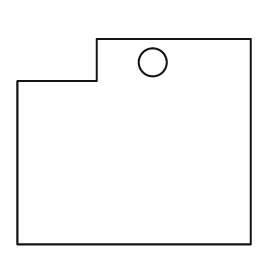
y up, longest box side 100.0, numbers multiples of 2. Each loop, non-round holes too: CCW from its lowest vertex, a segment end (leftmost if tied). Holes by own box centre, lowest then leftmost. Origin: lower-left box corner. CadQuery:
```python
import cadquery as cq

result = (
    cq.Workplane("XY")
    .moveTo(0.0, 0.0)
    .lineTo(100.0, 0.0)
    .lineTo(100.0, 88.0)
    .lineTo(34.0, 88.0)
    .lineTo(34.0, 70.0)
    .lineTo(0.0, 70.0)
    .close()
    .moveTo(58.0, 78.0)
    .circle(6.0)
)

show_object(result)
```